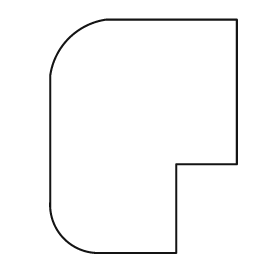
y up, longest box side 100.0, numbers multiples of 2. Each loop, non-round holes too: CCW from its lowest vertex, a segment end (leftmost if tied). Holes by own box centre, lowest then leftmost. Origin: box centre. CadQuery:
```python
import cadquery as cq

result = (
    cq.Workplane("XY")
    .moveTo(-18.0, -50.0)
    .lineTo(14.0, -50.0)
    .lineTo(14.0, -12.0)
    .lineTo(40.0, -12.0)
    .lineTo(40.0, 50.0)
    .lineTo(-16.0, 50.0)
    .threePointArc((-32.0, 42.0), (-40.0, 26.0))
    .lineTo(-40.0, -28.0)
    .threePointArc((-34.0, -44.0), (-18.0, -50.0))
    .close()
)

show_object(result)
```